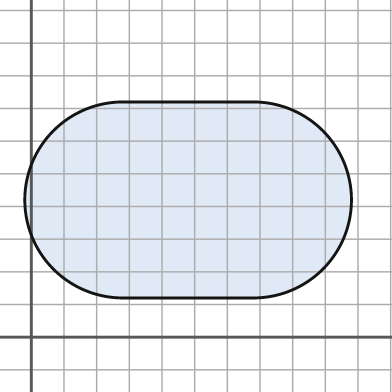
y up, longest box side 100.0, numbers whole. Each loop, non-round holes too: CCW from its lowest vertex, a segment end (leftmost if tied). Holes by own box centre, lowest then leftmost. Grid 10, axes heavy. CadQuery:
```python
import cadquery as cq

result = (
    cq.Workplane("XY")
    .moveTo(28.0, 12.0)
    .lineTo(68.0, 12.0)
    .threePointArc((98.0, 42.0), (68.0, 72.0))
    .lineTo(28.0, 72.0)
    .threePointArc((-2.0, 42.0), (28.0, 12.0))
    .close()
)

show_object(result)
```